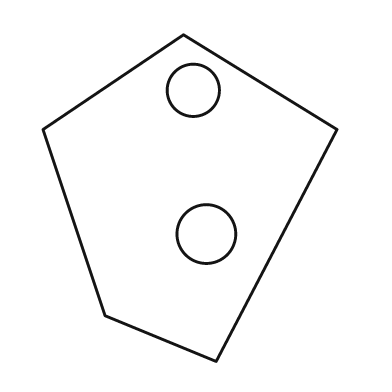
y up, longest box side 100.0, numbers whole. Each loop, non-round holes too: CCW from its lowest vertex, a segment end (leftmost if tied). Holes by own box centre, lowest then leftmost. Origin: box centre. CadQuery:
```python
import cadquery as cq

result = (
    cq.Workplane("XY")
    .moveTo(8.0, -50.0)
    .lineTo(45.0, 21.0)
    .lineTo(-2.0, 50.0)
    .lineTo(-45.0, 21.0)
    .lineTo(-26.0, -36.0)
    .close()
    .moveTo(5.0, -11.0)
    .circle(9.0)
    .moveTo(1.0, 33.0)
    .circle(8.0)
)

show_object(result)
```